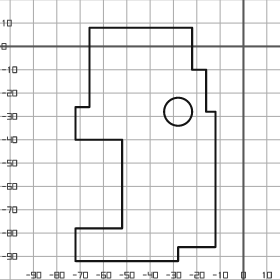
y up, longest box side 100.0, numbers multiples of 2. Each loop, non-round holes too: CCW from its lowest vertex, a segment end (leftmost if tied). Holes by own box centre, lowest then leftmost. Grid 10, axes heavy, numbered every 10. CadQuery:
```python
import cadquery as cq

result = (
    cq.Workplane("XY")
    .moveTo(-72.0, -92.0)
    .lineTo(-28.0, -92.0)
    .lineTo(-28.0, -86.0)
    .lineTo(-12.0, -86.0)
    .lineTo(-12.0, -28.0)
    .lineTo(-16.0, -28.0)
    .lineTo(-16.0, -10.0)
    .lineTo(-22.0, -10.0)
    .lineTo(-22.0, 8.0)
    .lineTo(-66.0, 8.0)
    .lineTo(-66.0, -26.0)
    .lineTo(-72.0, -26.0)
    .lineTo(-72.0, -40.0)
    .lineTo(-52.0, -40.0)
    .lineTo(-52.0, -78.0)
    .lineTo(-72.0, -78.0)
    .close()
    .moveTo(-28.0, -28.0)
    .circle(6.0)
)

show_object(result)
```